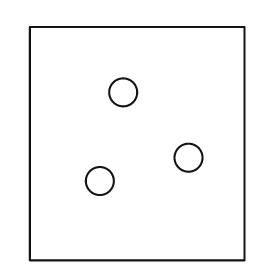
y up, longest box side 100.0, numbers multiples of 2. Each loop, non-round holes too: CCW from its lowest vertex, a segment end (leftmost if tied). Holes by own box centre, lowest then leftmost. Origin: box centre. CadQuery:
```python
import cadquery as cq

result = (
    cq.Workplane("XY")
    .moveTo(-46.0, -50.0)
    .lineTo(46.0, -50.0)
    .lineTo(46.0, 50.0)
    .lineTo(-46.0, 50.0)
    .close()
    .moveTo(-16.0, -16.0)
    .circle(6.0)
    .moveTo(22.0, -6.0)
    .circle(6.0)
    .moveTo(-6.0, 22.0)
    .circle(6.0)
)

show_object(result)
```